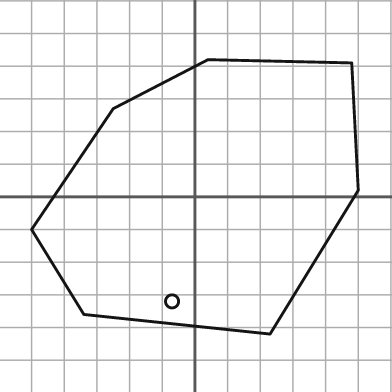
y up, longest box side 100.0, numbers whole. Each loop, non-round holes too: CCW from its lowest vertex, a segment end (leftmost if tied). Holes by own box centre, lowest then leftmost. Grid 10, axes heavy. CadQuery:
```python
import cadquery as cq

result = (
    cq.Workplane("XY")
    .moveTo(23.0, -42.0)
    .lineTo(50.0, 2.0)
    .lineTo(48.0, 41.0)
    .lineTo(4.0, 42.0)
    .lineTo(-25.0, 27.0)
    .lineTo(-50.0, -10.0)
    .lineTo(-34.0, -36.0)
    .close()
    .moveTo(-7.0, -32.0)
    .circle(2.0)
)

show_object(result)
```